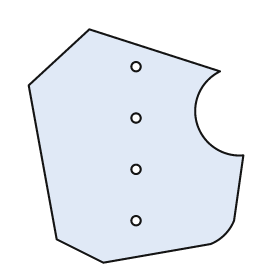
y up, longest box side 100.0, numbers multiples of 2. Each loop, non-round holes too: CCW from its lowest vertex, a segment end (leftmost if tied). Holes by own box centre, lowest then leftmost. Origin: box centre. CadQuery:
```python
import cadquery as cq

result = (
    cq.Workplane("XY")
    .moveTo(-14.0, -50.0)
    .lineTo(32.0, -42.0)
    .threePointArc((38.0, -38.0), (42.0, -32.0))
    .lineTo(46.0, -4.0)
    .threePointArc((26.0, 10.0), (36.0, 32.0))
    .lineTo(-20.0, 50.0)
    .lineTo(-46.0, 26.0)
    .lineTo(-34.0, -40.0)
    .close()
    .moveTo(0.0, -32.0)
    .circle(2.0)
    .moveTo(0.0, -10.0)
    .circle(2.0)
    .moveTo(0.0, 12.0)
    .circle(2.0)
    .moveTo(0.0, 34.0)
    .circle(2.0)
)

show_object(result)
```